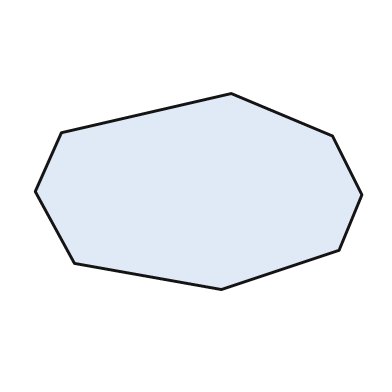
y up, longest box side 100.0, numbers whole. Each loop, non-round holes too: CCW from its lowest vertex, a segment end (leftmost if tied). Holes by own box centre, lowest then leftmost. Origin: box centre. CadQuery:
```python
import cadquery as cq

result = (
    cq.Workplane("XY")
    .moveTo(7.0, -30.0)
    .lineTo(43.0, -18.0)
    .lineTo(50.0, -1.0)
    .lineTo(41.0, 17.0)
    .lineTo(10.0, 30.0)
    .lineTo(-42.0, 18.0)
    .lineTo(-50.0, 0.0)
    .lineTo(-38.0, -22.0)
    .close()
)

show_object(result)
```